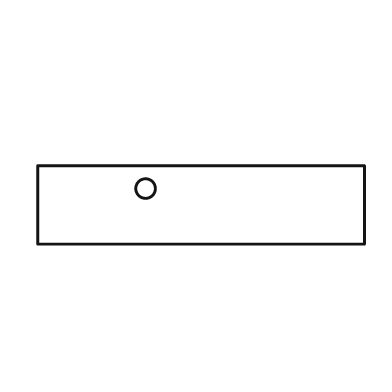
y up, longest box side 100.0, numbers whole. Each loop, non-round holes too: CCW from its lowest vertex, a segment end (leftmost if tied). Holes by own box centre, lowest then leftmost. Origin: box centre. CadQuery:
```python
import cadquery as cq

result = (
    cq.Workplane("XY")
    .moveTo(-50.0, -12.0)
    .lineTo(50.0, -12.0)
    .lineTo(50.0, 12.0)
    .lineTo(-50.0, 12.0)
    .close()
    .moveTo(-17.0, 5.0)
    .circle(3.0)
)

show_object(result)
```